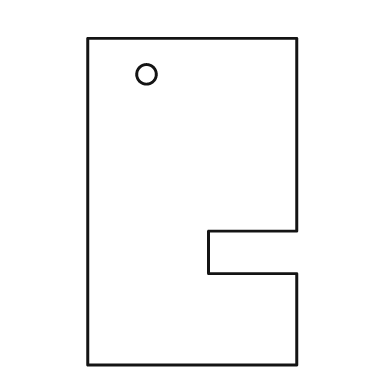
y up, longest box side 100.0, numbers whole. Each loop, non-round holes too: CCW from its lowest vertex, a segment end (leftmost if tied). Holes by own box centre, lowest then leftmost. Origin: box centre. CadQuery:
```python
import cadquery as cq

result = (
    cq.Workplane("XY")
    .moveTo(-32.0, -50.0)
    .lineTo(32.0, -50.0)
    .lineTo(32.0, -22.0)
    .lineTo(5.0, -22.0)
    .lineTo(5.0, -9.0)
    .lineTo(32.0, -9.0)
    .lineTo(32.0, 50.0)
    .lineTo(-32.0, 50.0)
    .close()
    .moveTo(-14.0, 39.0)
    .circle(3.0)
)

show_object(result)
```